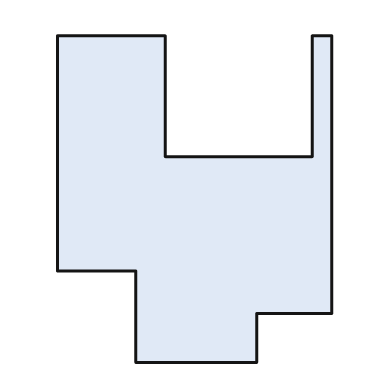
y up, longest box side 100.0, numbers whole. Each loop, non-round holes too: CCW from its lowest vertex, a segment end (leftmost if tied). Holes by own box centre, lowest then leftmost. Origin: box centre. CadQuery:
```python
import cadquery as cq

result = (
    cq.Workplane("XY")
    .moveTo(-18.0, -50.0)
    .lineTo(19.0, -50.0)
    .lineTo(19.0, -35.0)
    .lineTo(42.0, -35.0)
    .lineTo(42.0, 50.0)
    .lineTo(36.0, 50.0)
    .lineTo(36.0, 13.0)
    .lineTo(-9.0, 13.0)
    .lineTo(-9.0, 50.0)
    .lineTo(-42.0, 50.0)
    .lineTo(-42.0, -22.0)
    .lineTo(-18.0, -22.0)
    .close()
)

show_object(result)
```